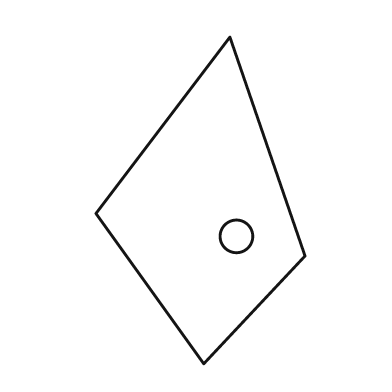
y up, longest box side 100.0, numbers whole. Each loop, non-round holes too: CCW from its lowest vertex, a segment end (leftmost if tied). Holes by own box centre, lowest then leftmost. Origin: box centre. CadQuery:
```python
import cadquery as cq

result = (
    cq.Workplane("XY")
    .moveTo(1.0, -50.0)
    .lineTo(32.0, -17.0)
    .lineTo(9.0, 50.0)
    .lineTo(-32.0, -4.0)
    .close()
    .moveTo(11.0, -11.0)
    .circle(5.0)
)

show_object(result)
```